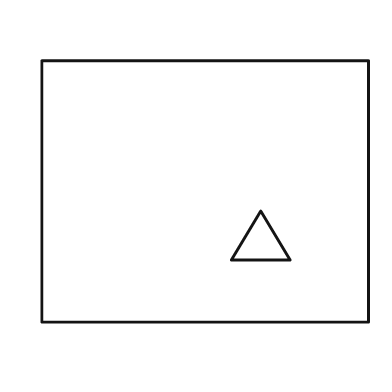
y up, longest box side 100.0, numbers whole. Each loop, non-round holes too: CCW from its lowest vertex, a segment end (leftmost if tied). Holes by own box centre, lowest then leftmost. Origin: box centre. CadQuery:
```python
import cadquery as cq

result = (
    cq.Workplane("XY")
    .moveTo(-50.0, -40.0)
    .lineTo(50.0, -40.0)
    .lineTo(50.0, 40.0)
    .lineTo(-50.0, 40.0)
    .close()
    .moveTo(8.0, -21.0)
    .lineTo(26.0, -21.0)
    .lineTo(17.0, -6.0)
    .close()
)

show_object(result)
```